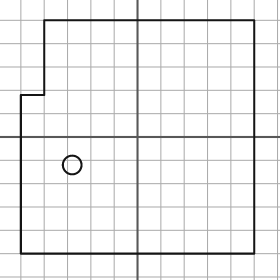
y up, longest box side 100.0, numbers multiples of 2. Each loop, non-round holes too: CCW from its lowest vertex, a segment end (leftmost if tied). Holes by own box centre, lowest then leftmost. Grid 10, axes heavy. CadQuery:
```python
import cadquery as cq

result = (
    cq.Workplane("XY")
    .moveTo(-50.0, -50.0)
    .lineTo(50.0, -50.0)
    .lineTo(50.0, 50.0)
    .lineTo(-40.0, 50.0)
    .lineTo(-40.0, 18.0)
    .lineTo(-50.0, 18.0)
    .close()
    .moveTo(-28.0, -12.0)
    .circle(4.0)
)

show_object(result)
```